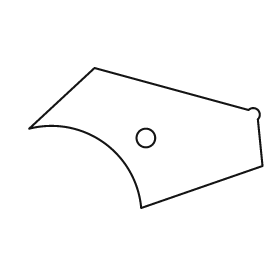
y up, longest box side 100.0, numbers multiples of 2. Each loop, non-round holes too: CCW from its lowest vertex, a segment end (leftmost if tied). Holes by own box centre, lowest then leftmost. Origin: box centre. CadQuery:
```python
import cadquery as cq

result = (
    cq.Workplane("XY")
    .moveTo(-2.0, -30.0)
    .lineTo(50.0, -12.0)
    .lineTo(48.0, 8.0)
    .threePointArc((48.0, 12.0), (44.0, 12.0))
    .lineTo(-22.0, 30.0)
    .lineTo(-50.0, 4.0)
    .threePointArc((-18.0, -2.0), (-2.0, -30.0))
    .close()
    .moveTo(0.0, 0.0)
    .circle(4.0)
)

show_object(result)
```